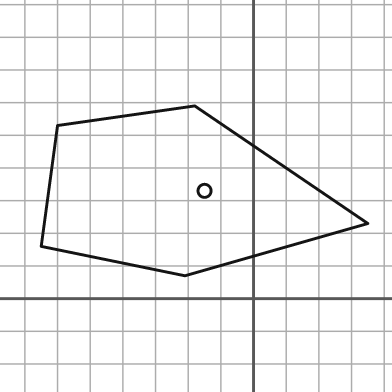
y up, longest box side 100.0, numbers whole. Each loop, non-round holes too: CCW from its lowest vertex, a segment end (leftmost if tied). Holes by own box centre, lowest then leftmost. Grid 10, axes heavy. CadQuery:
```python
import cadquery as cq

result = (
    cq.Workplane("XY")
    .moveTo(-21.0, 7.0)
    .lineTo(35.0, 23.0)
    .lineTo(-18.0, 59.0)
    .lineTo(-60.0, 53.0)
    .lineTo(-65.0, 16.0)
    .close()
    .moveTo(-15.0, 33.0)
    .circle(2.0)
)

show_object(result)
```